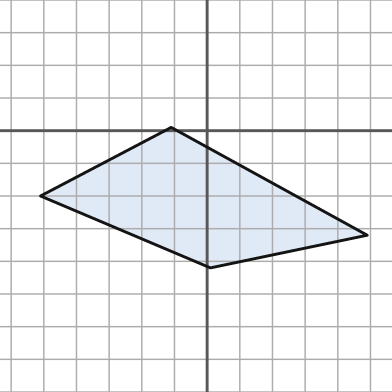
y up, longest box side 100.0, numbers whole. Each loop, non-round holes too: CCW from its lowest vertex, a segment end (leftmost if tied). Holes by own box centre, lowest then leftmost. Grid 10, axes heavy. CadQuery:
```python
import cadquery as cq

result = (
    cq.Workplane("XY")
    .moveTo(1.0, -42.0)
    .lineTo(49.0, -32.0)
    .lineTo(-11.0, 1.0)
    .lineTo(-51.0, -20.0)
    .close()
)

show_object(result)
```